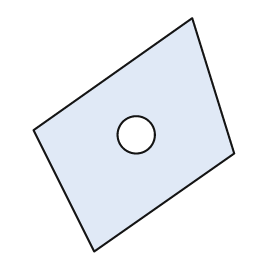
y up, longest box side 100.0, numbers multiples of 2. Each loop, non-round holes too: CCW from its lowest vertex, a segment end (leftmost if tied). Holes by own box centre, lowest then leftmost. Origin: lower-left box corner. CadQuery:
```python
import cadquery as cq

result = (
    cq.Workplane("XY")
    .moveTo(26.0, 0.0)
    .lineTo(86.0, 42.0)
    .lineTo(68.0, 100.0)
    .lineTo(0.0, 52.0)
    .close()
    .moveTo(44.0, 50.0)
    .circle(8.0)
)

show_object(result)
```